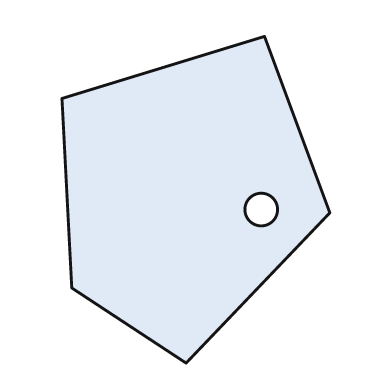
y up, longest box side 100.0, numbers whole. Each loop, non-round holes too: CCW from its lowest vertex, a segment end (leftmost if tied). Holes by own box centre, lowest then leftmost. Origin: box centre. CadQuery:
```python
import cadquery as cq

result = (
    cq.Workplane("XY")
    .moveTo(-3.0, -50.0)
    .lineTo(41.0, -4.0)
    .lineTo(21.0, 50.0)
    .lineTo(-41.0, 31.0)
    .lineTo(-38.0, -27.0)
    .close()
    .moveTo(20.0, -3.0)
    .circle(5.0)
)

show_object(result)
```